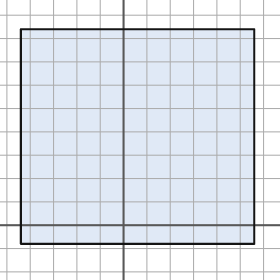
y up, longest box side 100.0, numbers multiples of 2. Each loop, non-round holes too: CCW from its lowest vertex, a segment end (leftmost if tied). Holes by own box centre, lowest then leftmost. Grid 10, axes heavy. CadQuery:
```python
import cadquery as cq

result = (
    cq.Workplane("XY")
    .moveTo(-44.0, -8.0)
    .lineTo(56.0, -8.0)
    .lineTo(56.0, 84.0)
    .lineTo(-44.0, 84.0)
    .close()
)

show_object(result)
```